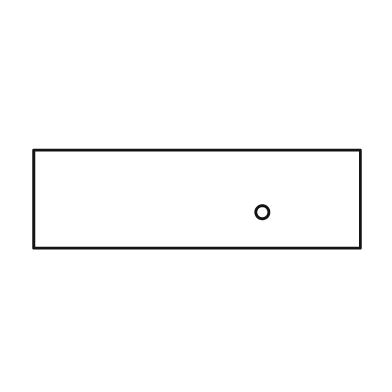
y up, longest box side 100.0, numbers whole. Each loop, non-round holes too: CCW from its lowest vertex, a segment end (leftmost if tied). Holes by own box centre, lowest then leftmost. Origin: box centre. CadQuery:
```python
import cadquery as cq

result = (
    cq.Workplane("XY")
    .moveTo(-50.0, -15.0)
    .lineTo(50.0, -15.0)
    .lineTo(50.0, 15.0)
    .lineTo(-50.0, 15.0)
    .close()
    .moveTo(20.0, -4.0)
    .circle(2.0)
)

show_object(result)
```